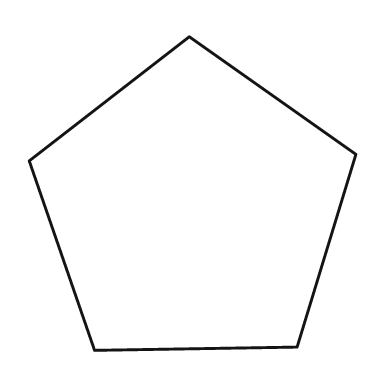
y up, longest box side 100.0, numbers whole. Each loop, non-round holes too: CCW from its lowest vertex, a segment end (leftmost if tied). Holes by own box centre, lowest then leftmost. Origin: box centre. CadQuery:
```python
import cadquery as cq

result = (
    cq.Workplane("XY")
    .moveTo(-30.0, -48.0)
    .lineTo(32.0, -47.0)
    .lineTo(50.0, 12.0)
    .lineTo(-1.0, 48.0)
    .lineTo(-50.0, 10.0)
    .close()
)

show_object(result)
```